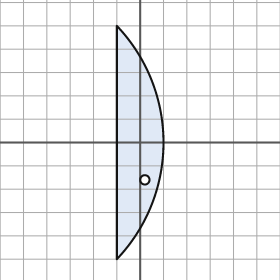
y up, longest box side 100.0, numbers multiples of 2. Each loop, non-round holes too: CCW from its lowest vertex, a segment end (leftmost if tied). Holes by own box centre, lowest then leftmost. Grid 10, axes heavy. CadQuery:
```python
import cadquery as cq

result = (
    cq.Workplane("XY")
    .moveTo(-10.0, -50.0)
    .threePointArc((10.0, 0.0), (-10.0, 50.0))
    .close()
    .moveTo(2.0, -16.0)
    .circle(2.0)
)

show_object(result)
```